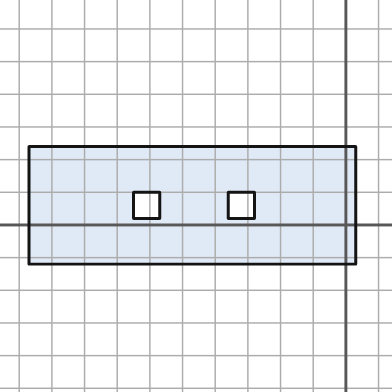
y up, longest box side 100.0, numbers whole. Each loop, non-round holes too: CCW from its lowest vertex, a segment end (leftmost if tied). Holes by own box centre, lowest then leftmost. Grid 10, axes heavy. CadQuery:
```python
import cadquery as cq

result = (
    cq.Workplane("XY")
    .moveTo(-97.0, -12.0)
    .lineTo(3.0, -12.0)
    .lineTo(3.0, 24.0)
    .lineTo(-97.0, 24.0)
    .close()
    .moveTo(-65.0, 2.0)
    .lineTo(-57.0, 2.0)
    .lineTo(-57.0, 10.0)
    .lineTo(-65.0, 10.0)
    .close()
    .moveTo(-36.0, 2.0)
    .lineTo(-28.0, 2.0)
    .lineTo(-28.0, 10.0)
    .lineTo(-36.0, 10.0)
    .close()
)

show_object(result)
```